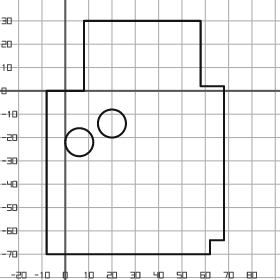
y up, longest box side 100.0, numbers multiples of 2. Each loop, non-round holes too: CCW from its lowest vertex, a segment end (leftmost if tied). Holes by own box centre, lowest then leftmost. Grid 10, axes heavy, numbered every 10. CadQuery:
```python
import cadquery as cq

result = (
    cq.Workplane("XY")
    .moveTo(-8.0, -70.0)
    .lineTo(62.0, -70.0)
    .lineTo(62.0, -64.0)
    .lineTo(68.0, -64.0)
    .lineTo(68.0, 2.0)
    .lineTo(58.0, 2.0)
    .lineTo(58.0, 30.0)
    .lineTo(8.0, 30.0)
    .lineTo(8.0, 0.0)
    .lineTo(-8.0, 0.0)
    .close()
    .moveTo(6.0, -22.0)
    .circle(6.0)
    .moveTo(20.0, -14.0)
    .circle(6.0)
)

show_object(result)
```